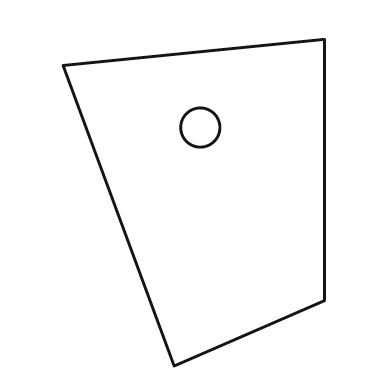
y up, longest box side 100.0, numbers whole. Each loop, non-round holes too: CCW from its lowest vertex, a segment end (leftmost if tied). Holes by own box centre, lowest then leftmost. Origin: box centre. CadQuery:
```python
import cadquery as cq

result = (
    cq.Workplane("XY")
    .moveTo(-6.0, -50.0)
    .lineTo(40.0, -30.0)
    .lineTo(40.0, 50.0)
    .lineTo(-40.0, 42.0)
    .close()
    .moveTo(2.0, 23.0)
    .circle(6.0)
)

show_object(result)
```